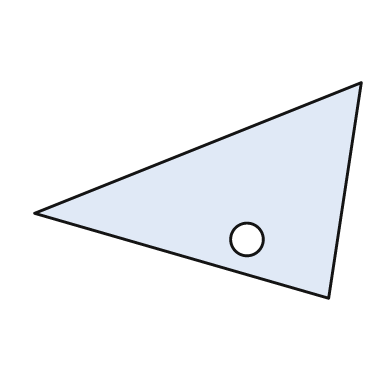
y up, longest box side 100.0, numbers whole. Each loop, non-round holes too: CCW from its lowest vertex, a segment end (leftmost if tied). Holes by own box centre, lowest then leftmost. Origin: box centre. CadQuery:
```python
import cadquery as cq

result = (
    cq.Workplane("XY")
    .moveTo(40.0, -33.0)
    .lineTo(50.0, 33.0)
    .lineTo(-50.0, -7.0)
    .close()
    .moveTo(15.0, -15.0)
    .circle(5.0)
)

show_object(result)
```